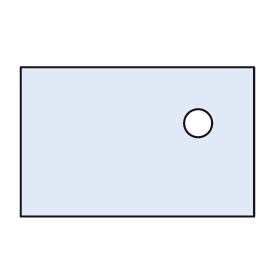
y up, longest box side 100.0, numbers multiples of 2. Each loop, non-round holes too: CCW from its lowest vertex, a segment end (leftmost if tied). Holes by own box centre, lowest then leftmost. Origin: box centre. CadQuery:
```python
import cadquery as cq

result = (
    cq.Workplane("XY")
    .moveTo(-50.0, -32.0)
    .lineTo(50.0, -32.0)
    .lineTo(50.0, 32.0)
    .lineTo(-50.0, 32.0)
    .close()
    .moveTo(26.0, 8.0)
    .circle(6.0)
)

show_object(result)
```